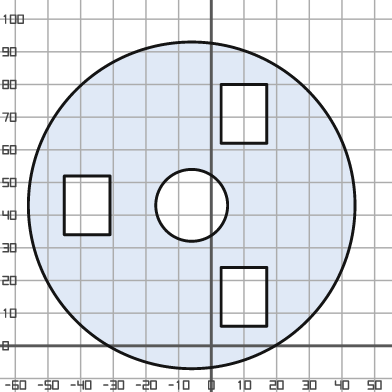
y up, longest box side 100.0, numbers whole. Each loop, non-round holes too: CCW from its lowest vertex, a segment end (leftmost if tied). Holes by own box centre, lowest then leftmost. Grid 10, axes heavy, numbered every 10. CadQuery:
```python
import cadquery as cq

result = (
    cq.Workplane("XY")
    .moveTo(-6.0, 43.0)
    .circle(50.0)
    .moveTo(3.0, 6.0)
    .lineTo(17.0, 6.0)
    .lineTo(17.0, 24.0)
    .lineTo(3.0, 24.0)
    .close()
    .moveTo(-45.0, 34.0)
    .lineTo(-31.0, 34.0)
    .lineTo(-31.0, 52.0)
    .lineTo(-45.0, 52.0)
    .close()
    .moveTo(-6.0, 43.0)
    .circle(11.0)
    .moveTo(3.0, 62.0)
    .lineTo(17.0, 62.0)
    .lineTo(17.0, 80.0)
    .lineTo(3.0, 80.0)
    .close()
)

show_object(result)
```